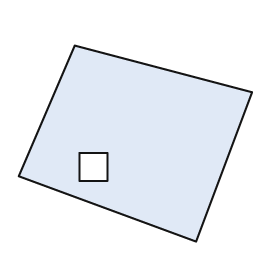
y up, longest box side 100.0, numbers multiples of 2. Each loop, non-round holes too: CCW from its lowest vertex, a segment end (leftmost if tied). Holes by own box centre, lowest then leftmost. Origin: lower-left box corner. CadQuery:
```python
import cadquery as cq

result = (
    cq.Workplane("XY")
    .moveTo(76.0, 0.0)
    .lineTo(100.0, 64.0)
    .lineTo(24.0, 84.0)
    .lineTo(0.0, 28.0)
    .close()
    .moveTo(26.0, 26.0)
    .lineTo(38.0, 26.0)
    .lineTo(38.0, 38.0)
    .lineTo(26.0, 38.0)
    .close()
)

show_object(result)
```